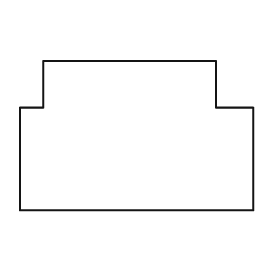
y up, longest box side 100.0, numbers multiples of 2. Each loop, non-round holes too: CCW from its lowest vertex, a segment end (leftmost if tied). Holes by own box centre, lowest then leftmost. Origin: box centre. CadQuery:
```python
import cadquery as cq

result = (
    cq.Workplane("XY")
    .moveTo(-50.0, -32.0)
    .lineTo(50.0, -32.0)
    .lineTo(50.0, 12.0)
    .lineTo(34.0, 12.0)
    .lineTo(34.0, 32.0)
    .lineTo(-40.0, 32.0)
    .lineTo(-40.0, 12.0)
    .lineTo(-50.0, 12.0)
    .close()
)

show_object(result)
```